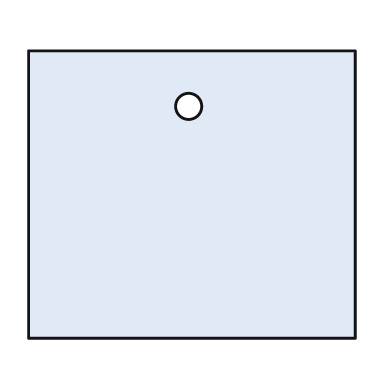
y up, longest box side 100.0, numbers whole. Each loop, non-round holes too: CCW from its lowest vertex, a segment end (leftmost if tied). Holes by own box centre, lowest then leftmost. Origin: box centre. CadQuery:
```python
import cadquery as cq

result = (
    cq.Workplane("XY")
    .moveTo(-50.0, -44.0)
    .lineTo(50.0, -44.0)
    .lineTo(50.0, 44.0)
    .lineTo(-50.0, 44.0)
    .close()
    .moveTo(-1.0, 27.0)
    .circle(4.0)
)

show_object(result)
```